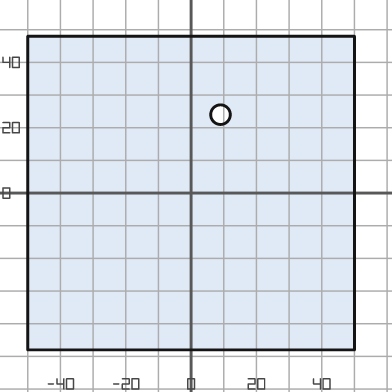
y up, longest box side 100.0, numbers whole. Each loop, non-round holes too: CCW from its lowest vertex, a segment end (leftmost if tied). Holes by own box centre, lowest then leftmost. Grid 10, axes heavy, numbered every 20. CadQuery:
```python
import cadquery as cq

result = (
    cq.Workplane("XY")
    .moveTo(-50.0, -48.0)
    .lineTo(50.0, -48.0)
    .lineTo(50.0, 48.0)
    .lineTo(-50.0, 48.0)
    .close()
    .moveTo(9.0, 24.0)
    .circle(3.0)
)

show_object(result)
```